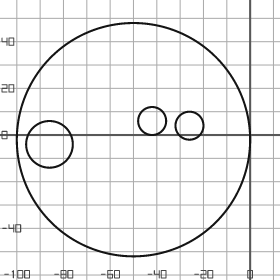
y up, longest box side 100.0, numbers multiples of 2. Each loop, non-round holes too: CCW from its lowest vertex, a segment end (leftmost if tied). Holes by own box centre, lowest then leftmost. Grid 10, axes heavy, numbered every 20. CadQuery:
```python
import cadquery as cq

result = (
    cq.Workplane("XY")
    .moveTo(-50.0, -2.0)
    .circle(50.0)
    .moveTo(-86.0, -4.0)
    .circle(10.0)
    .moveTo(-26.0, 4.0)
    .circle(6.0)
    .moveTo(-42.0, 6.0)
    .circle(6.0)
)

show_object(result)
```